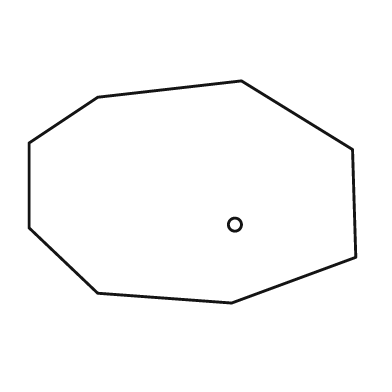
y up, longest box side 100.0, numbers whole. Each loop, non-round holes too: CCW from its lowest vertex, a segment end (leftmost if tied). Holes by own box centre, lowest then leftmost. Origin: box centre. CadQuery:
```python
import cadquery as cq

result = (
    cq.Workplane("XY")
    .moveTo(12.0, -34.0)
    .lineTo(50.0, -20.0)
    .lineTo(49.0, 13.0)
    .lineTo(15.0, 34.0)
    .lineTo(-29.0, 29.0)
    .lineTo(-50.0, 15.0)
    .lineTo(-50.0, -11.0)
    .lineTo(-29.0, -31.0)
    .close()
    .moveTo(13.0, -10.0)
    .circle(2.0)
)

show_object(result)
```